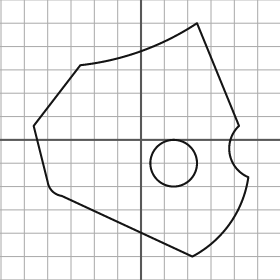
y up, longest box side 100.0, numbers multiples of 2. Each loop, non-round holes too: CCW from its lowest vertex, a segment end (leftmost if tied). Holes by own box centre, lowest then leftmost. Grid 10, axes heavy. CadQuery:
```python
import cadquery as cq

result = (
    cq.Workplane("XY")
    .moveTo(22.0, -50.0)
    .threePointArc((38.0, -36.0), (46.0, -16.0))
    .threePointArc((38.0, -6.0), (42.0, 6.0))
    .lineTo(24.0, 50.0)
    .threePointArc((0.0, 38.0), (-26.0, 32.0))
    .lineTo(-46.0, 6.0)
    .lineTo(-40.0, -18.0)
    .threePointArc((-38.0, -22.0), (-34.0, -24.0))
    .close()
    .moveTo(14.0, -10.0)
    .circle(10.0)
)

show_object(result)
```